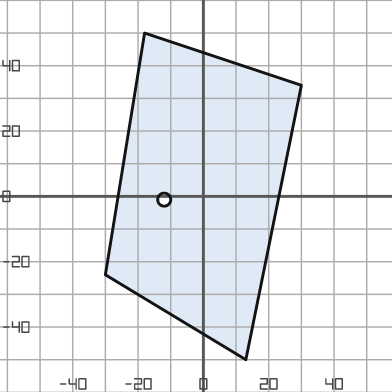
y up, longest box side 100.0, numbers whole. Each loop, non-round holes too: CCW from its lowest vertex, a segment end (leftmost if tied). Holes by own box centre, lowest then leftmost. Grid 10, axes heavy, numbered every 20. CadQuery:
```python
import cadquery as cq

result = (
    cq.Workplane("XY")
    .moveTo(13.0, -50.0)
    .lineTo(30.0, 34.0)
    .lineTo(-18.0, 50.0)
    .lineTo(-30.0, -24.0)
    .close()
    .moveTo(-12.0, -1.0)
    .circle(2.0)
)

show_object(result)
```